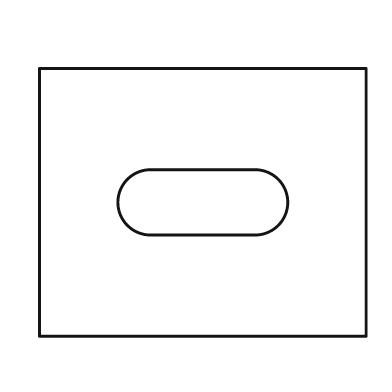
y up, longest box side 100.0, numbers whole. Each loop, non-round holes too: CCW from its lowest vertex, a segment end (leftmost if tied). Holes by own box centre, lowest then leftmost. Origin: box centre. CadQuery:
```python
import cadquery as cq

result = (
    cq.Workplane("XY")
    .moveTo(-50.0, -41.0)
    .lineTo(50.0, -41.0)
    .lineTo(50.0, 41.0)
    .lineTo(-50.0, 41.0)
    .close()
    .moveTo(-16.0, -10.0)
    .lineTo(16.0, -10.0)
    .threePointArc((26.0, 0.0), (16.0, 10.0))
    .lineTo(-16.0, 10.0)
    .threePointArc((-26.0, 0.0), (-16.0, -10.0))
    .close()
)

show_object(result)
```